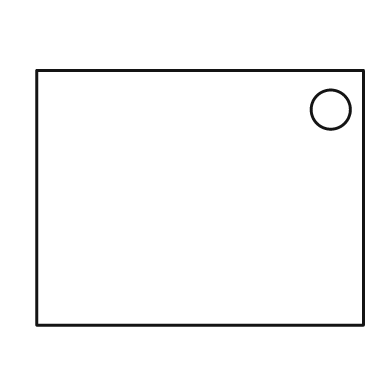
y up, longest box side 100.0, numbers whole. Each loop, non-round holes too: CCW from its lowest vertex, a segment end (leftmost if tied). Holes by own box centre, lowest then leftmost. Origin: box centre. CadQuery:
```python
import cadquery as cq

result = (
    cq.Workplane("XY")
    .moveTo(-50.0, -39.0)
    .lineTo(50.0, -39.0)
    .lineTo(50.0, 39.0)
    .lineTo(-50.0, 39.0)
    .close()
    .moveTo(40.0, 27.0)
    .circle(6.0)
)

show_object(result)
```